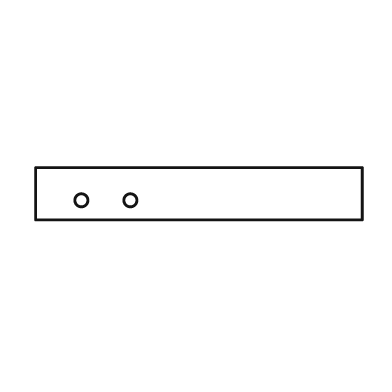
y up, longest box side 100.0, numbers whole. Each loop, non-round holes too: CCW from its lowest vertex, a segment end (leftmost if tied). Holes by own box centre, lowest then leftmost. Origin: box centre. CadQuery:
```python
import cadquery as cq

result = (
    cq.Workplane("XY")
    .moveTo(-50.0, -8.0)
    .lineTo(50.0, -8.0)
    .lineTo(50.0, 8.0)
    .lineTo(-50.0, 8.0)
    .close()
    .moveTo(-36.0, -2.0)
    .circle(2.0)
    .moveTo(-21.0, -2.0)
    .circle(2.0)
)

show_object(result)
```